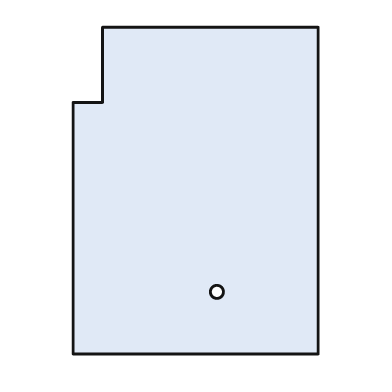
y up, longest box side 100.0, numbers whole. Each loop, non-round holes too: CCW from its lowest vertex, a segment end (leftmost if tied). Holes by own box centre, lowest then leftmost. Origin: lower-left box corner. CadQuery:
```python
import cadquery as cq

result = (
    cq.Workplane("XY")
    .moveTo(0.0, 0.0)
    .lineTo(75.0, 0.0)
    .lineTo(75.0, 100.0)
    .lineTo(9.0, 100.0)
    .lineTo(9.0, 77.0)
    .lineTo(0.0, 77.0)
    .close()
    .moveTo(44.0, 19.0)
    .circle(2.0)
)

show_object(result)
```